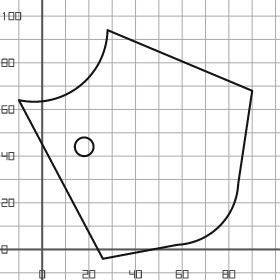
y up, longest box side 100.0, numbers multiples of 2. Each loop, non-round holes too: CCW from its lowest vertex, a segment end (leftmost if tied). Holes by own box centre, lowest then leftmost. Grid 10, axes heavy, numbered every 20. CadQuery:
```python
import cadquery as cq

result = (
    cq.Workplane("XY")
    .moveTo(26.0, -4.0)
    .lineTo(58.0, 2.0)
    .threePointArc((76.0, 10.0), (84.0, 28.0))
    .lineTo(90.0, 68.0)
    .lineTo(28.0, 94.0)
    .threePointArc((16.0, 70.0), (-10.0, 64.0))
    .close()
    .moveTo(18.0, 44.0)
    .circle(4.0)
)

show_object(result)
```